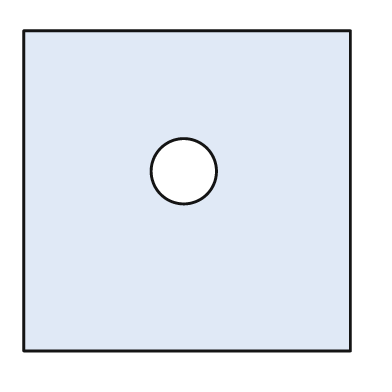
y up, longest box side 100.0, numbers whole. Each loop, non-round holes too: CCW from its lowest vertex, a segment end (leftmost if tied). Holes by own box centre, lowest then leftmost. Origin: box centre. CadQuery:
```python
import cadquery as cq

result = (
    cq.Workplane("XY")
    .moveTo(-50.0, -49.0)
    .lineTo(50.0, -49.0)
    .lineTo(50.0, 49.0)
    .lineTo(-50.0, 49.0)
    .close()
    .moveTo(-1.0, 6.0)
    .circle(10.0)
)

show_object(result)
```